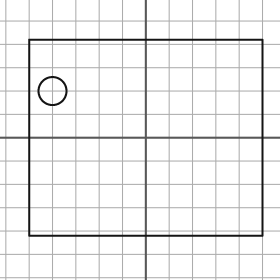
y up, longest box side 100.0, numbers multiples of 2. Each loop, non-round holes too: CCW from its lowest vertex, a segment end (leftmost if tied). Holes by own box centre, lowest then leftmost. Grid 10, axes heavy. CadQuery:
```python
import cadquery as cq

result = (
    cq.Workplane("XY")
    .moveTo(-50.0, -42.0)
    .lineTo(50.0, -42.0)
    .lineTo(50.0, 42.0)
    .lineTo(-50.0, 42.0)
    .close()
    .moveTo(-40.0, 20.0)
    .circle(6.0)
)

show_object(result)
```